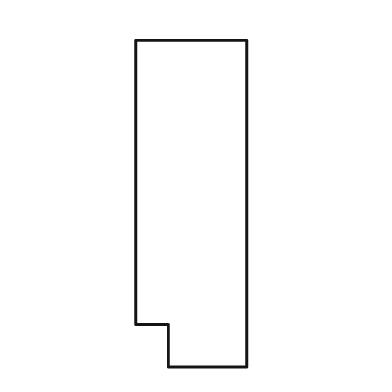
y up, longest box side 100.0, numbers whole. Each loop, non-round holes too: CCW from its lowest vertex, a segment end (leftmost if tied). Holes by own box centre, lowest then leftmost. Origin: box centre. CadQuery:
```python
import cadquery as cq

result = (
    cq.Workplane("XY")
    .moveTo(-7.0, -50.0)
    .lineTo(17.0, -50.0)
    .lineTo(17.0, 50.0)
    .lineTo(-17.0, 50.0)
    .lineTo(-17.0, -37.0)
    .lineTo(-7.0, -37.0)
    .close()
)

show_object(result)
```